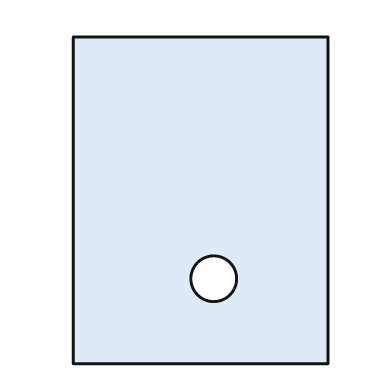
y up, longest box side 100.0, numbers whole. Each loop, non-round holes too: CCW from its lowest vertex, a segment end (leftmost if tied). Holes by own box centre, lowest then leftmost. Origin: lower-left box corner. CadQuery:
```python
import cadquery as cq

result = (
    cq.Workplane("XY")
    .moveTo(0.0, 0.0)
    .lineTo(78.0, 0.0)
    .lineTo(78.0, 100.0)
    .lineTo(0.0, 100.0)
    .close()
    .moveTo(43.0, 26.0)
    .circle(7.0)
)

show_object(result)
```